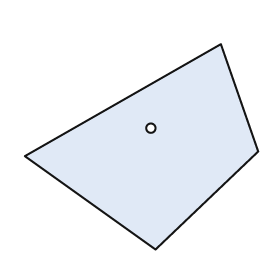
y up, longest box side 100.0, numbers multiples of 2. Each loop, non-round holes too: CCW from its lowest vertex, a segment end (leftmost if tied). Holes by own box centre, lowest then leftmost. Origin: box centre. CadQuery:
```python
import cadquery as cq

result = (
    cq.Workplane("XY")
    .moveTo(6.0, -44.0)
    .lineTo(50.0, -2.0)
    .lineTo(34.0, 44.0)
    .lineTo(-50.0, -4.0)
    .close()
    .moveTo(4.0, 8.0)
    .circle(2.0)
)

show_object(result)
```